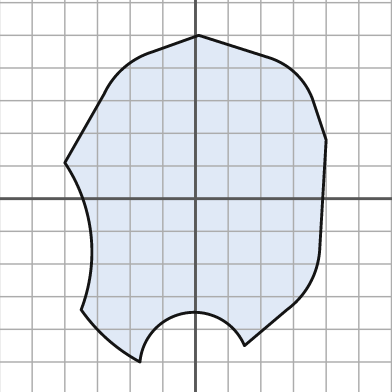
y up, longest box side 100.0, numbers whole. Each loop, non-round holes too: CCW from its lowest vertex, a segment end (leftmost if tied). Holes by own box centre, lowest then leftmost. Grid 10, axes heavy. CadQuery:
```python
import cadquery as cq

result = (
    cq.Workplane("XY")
    .moveTo(-17.0, -50.0)
    .threePointArc((-3.0, -35.0), (15.0, -45.0))
    .lineTo(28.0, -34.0)
    .threePointArc((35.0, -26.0), (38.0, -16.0))
    .lineTo(40.0, 18.0)
    .lineTo(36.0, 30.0)
    .threePointArc((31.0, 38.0), (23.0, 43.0))
    .lineTo(1.0, 50.0)
    .lineTo(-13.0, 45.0)
    .threePointArc((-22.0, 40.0), (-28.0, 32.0))
    .lineTo(-40.0, 11.0)
    .threePointArc((-32.0, -11.0), (-35.0, -34.0))
    .threePointArc((-27.0, -43.0), (-17.0, -50.0))
    .close()
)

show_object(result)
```